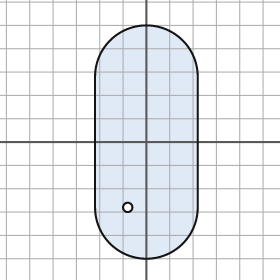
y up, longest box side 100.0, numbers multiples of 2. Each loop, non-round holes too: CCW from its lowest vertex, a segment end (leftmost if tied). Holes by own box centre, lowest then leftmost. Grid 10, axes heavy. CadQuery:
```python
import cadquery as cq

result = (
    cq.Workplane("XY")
    .moveTo(-22.0, -28.0)
    .threePointArc((0.0, -50.0), (22.0, -28.0))
    .lineTo(22.0, 28.0)
    .threePointArc((0.0, 50.0), (-22.0, 28.0))
    .close()
    .moveTo(-8.0, -28.0)
    .circle(2.0)
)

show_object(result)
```